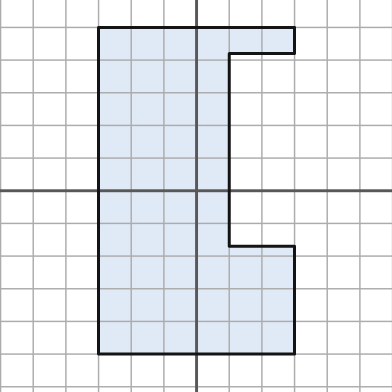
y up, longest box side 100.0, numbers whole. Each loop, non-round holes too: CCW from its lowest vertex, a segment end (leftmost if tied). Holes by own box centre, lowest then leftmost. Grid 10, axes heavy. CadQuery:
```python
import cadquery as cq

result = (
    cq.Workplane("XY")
    .moveTo(-30.0, -50.0)
    .lineTo(30.0, -50.0)
    .lineTo(30.0, -17.0)
    .lineTo(10.0, -17.0)
    .lineTo(10.0, 42.0)
    .lineTo(30.0, 42.0)
    .lineTo(30.0, 50.0)
    .lineTo(-30.0, 50.0)
    .close()
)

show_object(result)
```